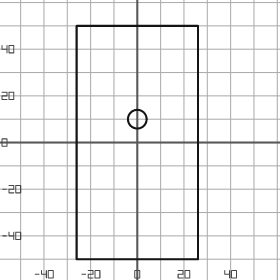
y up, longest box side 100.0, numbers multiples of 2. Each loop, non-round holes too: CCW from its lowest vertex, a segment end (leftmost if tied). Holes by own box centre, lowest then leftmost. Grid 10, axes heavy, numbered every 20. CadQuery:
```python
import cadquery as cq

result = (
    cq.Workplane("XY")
    .moveTo(-26.0, -50.0)
    .lineTo(26.0, -50.0)
    .lineTo(26.0, 50.0)
    .lineTo(-26.0, 50.0)
    .close()
    .moveTo(0.0, 10.0)
    .circle(4.0)
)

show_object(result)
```